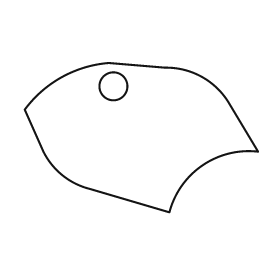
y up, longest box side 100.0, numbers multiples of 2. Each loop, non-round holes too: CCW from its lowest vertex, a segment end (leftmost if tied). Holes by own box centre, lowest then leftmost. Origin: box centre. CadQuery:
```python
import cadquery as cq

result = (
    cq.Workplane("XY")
    .moveTo(12.0, -32.0)
    .threePointArc((26.0, -12.0), (50.0, -6.0))
    .lineTo(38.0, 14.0)
    .threePointArc((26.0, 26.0), (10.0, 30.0))
    .lineTo(-14.0, 32.0)
    .threePointArc((-34.0, 26.0), (-50.0, 12.0))
    .lineTo(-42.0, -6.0)
    .threePointArc((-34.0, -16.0), (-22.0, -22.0))
    .close()
    .moveTo(-12.0, 22.0)
    .circle(6.0)
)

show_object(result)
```